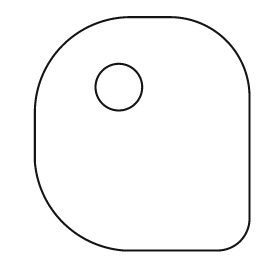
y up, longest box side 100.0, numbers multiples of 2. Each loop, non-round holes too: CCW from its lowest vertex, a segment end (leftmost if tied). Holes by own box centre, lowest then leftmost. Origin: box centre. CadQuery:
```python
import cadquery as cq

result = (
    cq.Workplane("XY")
    .moveTo(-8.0, -50.0)
    .lineTo(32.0, -50.0)
    .threePointArc((42.0, -46.0), (46.0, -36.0))
    .lineTo(46.0, 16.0)
    .threePointArc((36.0, 40.0), (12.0, 50.0))
    .lineTo(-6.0, 50.0)
    .threePointArc((-34.0, 38.0), (-46.0, 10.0))
    .lineTo(-46.0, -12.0)
    .threePointArc((-34.0, -38.0), (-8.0, -50.0))
    .close()
    .moveTo(-10.0, 20.0)
    .circle(10.0)
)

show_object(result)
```